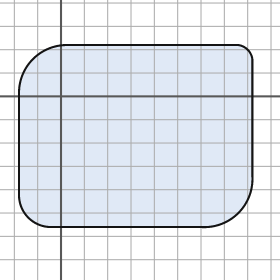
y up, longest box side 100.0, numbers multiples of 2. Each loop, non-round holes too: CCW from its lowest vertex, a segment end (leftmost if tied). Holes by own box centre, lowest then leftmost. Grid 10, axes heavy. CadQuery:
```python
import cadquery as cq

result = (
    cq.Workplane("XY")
    .moveTo(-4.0, -56.0)
    .lineTo(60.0, -56.0)
    .threePointArc((76.0, -50.0), (82.0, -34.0))
    .lineTo(82.0, 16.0)
    .threePointArc((80.0, 20.0), (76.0, 22.0))
    .lineTo(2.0, 22.0)
    .threePointArc((-12.0, 16.0), (-18.0, 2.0))
    .lineTo(-18.0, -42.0)
    .threePointArc((-14.0, -52.0), (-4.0, -56.0))
    .close()
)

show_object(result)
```